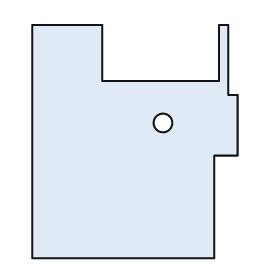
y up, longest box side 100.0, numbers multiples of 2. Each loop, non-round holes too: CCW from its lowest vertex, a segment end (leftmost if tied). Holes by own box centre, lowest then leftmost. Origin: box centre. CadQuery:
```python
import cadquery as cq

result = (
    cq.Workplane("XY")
    .moveTo(-44.0, -50.0)
    .lineTo(34.0, -50.0)
    .lineTo(34.0, -6.0)
    .lineTo(44.0, -6.0)
    .lineTo(44.0, 20.0)
    .lineTo(40.0, 20.0)
    .lineTo(40.0, 50.0)
    .lineTo(36.0, 50.0)
    .lineTo(36.0, 26.0)
    .lineTo(-14.0, 26.0)
    .lineTo(-14.0, 50.0)
    .lineTo(-44.0, 50.0)
    .close()
    .moveTo(12.0, 8.0)
    .circle(4.0)
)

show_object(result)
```